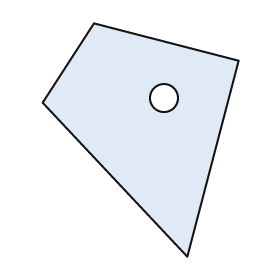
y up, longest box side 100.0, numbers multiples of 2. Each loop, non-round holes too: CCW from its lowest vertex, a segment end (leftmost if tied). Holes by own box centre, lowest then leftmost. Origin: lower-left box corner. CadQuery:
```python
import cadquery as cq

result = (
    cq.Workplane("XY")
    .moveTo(62.0, 0.0)
    .lineTo(84.0, 84.0)
    .lineTo(22.0, 100.0)
    .lineTo(0.0, 66.0)
    .close()
    .moveTo(52.0, 68.0)
    .circle(6.0)
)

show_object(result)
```